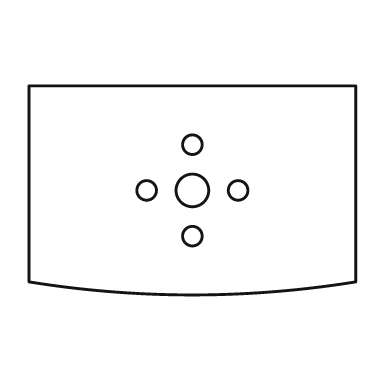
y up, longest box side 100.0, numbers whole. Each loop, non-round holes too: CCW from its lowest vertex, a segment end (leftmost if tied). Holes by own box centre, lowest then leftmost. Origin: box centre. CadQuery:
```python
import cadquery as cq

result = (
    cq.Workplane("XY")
    .moveTo(-50.0, -28.0)
    .threePointArc((0.0, -32.0), (50.0, -28.0))
    .lineTo(50.0, 32.0)
    .lineTo(-50.0, 32.0)
    .close()
    .moveTo(0.0, -14.0)
    .circle(3.0)
    .moveTo(-14.0, 0.0)
    .circle(3.0)
    .moveTo(0.0, 0.0)
    .circle(5.0)
    .moveTo(14.0, 0.0)
    .circle(3.0)
    .moveTo(0.0, 14.0)
    .circle(3.0)
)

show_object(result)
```